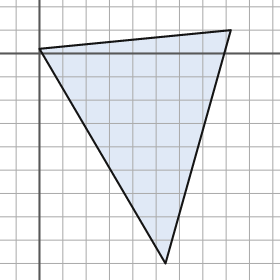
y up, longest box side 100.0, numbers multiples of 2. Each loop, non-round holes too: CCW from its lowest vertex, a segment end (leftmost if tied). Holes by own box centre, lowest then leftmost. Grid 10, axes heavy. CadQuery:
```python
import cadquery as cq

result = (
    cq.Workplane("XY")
    .moveTo(54.0, -90.0)
    .lineTo(82.0, 10.0)
    .lineTo(0.0, 2.0)
    .close()
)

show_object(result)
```